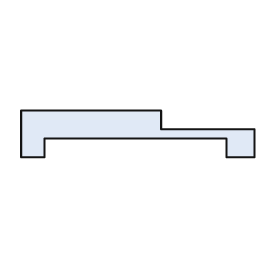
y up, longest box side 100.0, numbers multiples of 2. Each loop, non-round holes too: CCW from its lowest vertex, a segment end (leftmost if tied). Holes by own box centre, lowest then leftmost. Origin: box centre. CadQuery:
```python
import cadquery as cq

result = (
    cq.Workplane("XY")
    .moveTo(-50.0, -10.0)
    .lineTo(-40.0, -10.0)
    .lineTo(-40.0, -2.0)
    .lineTo(38.0, -2.0)
    .lineTo(38.0, -10.0)
    .lineTo(50.0, -10.0)
    .lineTo(50.0, 2.0)
    .lineTo(10.0, 2.0)
    .lineTo(10.0, 10.0)
    .lineTo(-50.0, 10.0)
    .close()
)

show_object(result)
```